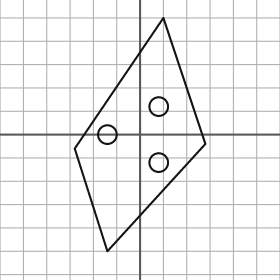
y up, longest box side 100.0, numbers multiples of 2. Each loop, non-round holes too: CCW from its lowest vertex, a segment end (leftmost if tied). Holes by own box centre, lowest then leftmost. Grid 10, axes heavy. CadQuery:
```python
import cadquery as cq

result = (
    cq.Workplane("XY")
    .moveTo(-14.0, -50.0)
    .lineTo(28.0, -4.0)
    .lineTo(10.0, 50.0)
    .lineTo(-28.0, -6.0)
    .close()
    .moveTo(8.0, -12.0)
    .circle(4.0)
    .moveTo(-14.0, 0.0)
    .circle(4.0)
    .moveTo(8.0, 12.0)
    .circle(4.0)
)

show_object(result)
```